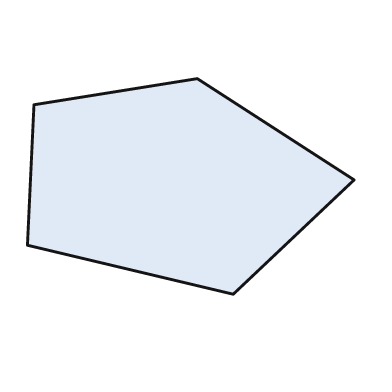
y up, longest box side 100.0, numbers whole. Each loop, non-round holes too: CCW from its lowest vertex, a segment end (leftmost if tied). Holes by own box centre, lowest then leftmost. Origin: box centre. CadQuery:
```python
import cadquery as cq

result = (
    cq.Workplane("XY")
    .moveTo(13.0, -33.0)
    .lineTo(50.0, 2.0)
    .lineTo(2.0, 33.0)
    .lineTo(-48.0, 25.0)
    .lineTo(-50.0, -18.0)
    .close()
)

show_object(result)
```